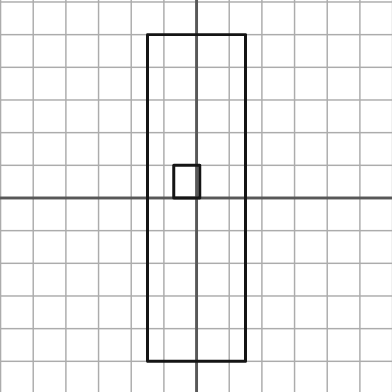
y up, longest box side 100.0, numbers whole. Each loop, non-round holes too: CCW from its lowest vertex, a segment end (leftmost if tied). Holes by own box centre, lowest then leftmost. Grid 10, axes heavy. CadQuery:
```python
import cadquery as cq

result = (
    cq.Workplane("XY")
    .moveTo(-15.0, -50.0)
    .lineTo(15.0, -50.0)
    .lineTo(15.0, 50.0)
    .lineTo(-15.0, 50.0)
    .close()
    .moveTo(-7.0, 0.0)
    .lineTo(1.0, 0.0)
    .lineTo(1.0, 10.0)
    .lineTo(-7.0, 10.0)
    .close()
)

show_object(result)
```